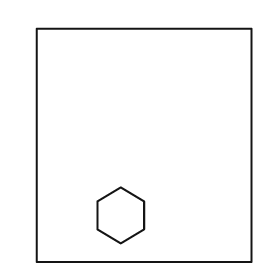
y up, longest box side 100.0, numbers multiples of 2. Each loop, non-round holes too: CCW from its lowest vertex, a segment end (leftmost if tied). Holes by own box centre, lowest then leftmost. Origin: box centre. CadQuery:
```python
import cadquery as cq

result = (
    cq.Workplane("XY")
    .moveTo(-46.0, -50.0)
    .lineTo(46.0, -50.0)
    .lineTo(46.0, 50.0)
    .lineTo(-46.0, 50.0)
    .close()
    .moveTo(-10.0, -42.0)
    .lineTo(0.0, -36.0)
    .lineTo(0.0, -24.0)
    .lineTo(-10.0, -18.0)
    .lineTo(-20.0, -24.0)
    .lineTo(-20.0, -36.0)
    .close()
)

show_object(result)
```